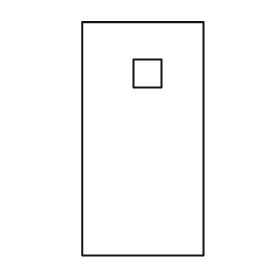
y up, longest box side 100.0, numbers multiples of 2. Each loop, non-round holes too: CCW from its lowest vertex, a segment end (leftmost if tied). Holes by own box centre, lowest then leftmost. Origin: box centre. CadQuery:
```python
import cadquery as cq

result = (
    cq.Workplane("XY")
    .moveTo(-26.0, -50.0)
    .lineTo(26.0, -50.0)
    .lineTo(26.0, 50.0)
    .lineTo(-26.0, 50.0)
    .close()
    .moveTo(-4.0, 22.0)
    .lineTo(8.0, 22.0)
    .lineTo(8.0, 34.0)
    .lineTo(-4.0, 34.0)
    .close()
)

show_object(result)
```